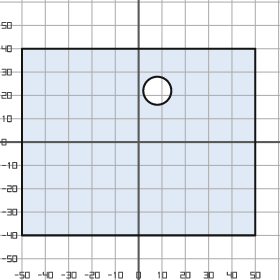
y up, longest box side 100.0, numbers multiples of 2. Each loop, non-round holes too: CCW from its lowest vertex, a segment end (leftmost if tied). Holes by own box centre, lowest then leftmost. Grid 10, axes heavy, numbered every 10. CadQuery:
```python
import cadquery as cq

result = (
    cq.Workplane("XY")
    .moveTo(-50.0, -40.0)
    .lineTo(50.0, -40.0)
    .lineTo(50.0, 40.0)
    .lineTo(-50.0, 40.0)
    .close()
    .moveTo(8.0, 22.0)
    .circle(6.0)
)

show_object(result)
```